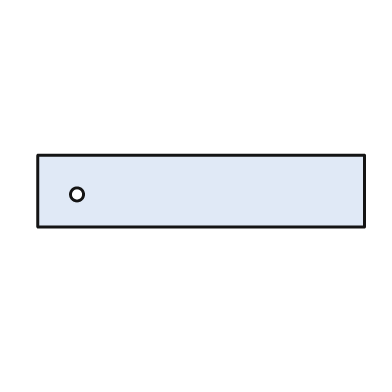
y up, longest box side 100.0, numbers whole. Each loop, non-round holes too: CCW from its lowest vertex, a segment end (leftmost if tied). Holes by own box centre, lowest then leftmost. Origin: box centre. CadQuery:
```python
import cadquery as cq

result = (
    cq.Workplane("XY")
    .moveTo(-50.0, -11.0)
    .lineTo(50.0, -11.0)
    .lineTo(50.0, 11.0)
    .lineTo(-50.0, 11.0)
    .close()
    .moveTo(-38.0, -1.0)
    .circle(2.0)
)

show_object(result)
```